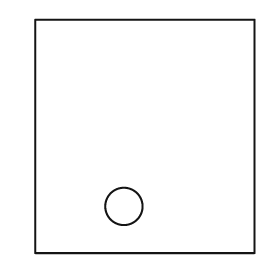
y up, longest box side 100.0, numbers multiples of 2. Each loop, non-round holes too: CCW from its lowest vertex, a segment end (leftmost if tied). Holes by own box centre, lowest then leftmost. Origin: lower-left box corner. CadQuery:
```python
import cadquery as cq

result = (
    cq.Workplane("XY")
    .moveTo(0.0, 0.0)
    .lineTo(94.0, 0.0)
    .lineTo(94.0, 100.0)
    .lineTo(0.0, 100.0)
    .close()
    .moveTo(38.0, 20.0)
    .circle(8.0)
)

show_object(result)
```